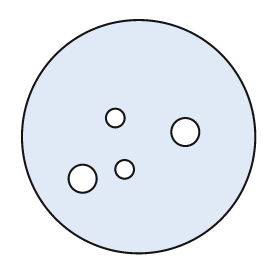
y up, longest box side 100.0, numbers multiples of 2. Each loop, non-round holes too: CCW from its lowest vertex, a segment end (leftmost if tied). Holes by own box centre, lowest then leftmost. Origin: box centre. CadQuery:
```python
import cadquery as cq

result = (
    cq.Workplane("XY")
    .moveTo(0.0, 0.0)
    .circle(50.0)
    .moveTo(-24.0, -18.0)
    .circle(6.0)
    .moveTo(-6.0, -14.0)
    .circle(4.0)
    .moveTo(20.0, 2.0)
    .circle(6.0)
    .moveTo(-10.0, 8.0)
    .circle(4.0)
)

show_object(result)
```